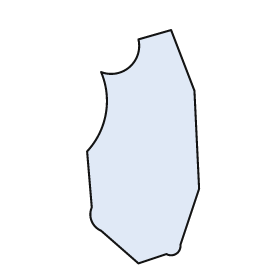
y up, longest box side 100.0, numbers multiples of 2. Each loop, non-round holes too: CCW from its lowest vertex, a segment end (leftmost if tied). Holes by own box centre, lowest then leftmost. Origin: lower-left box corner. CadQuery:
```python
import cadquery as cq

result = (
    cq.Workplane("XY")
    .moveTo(22.0, 0.0)
    .lineTo(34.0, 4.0)
    .threePointArc((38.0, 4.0), (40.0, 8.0))
    .lineTo(48.0, 32.0)
    .lineTo(46.0, 74.0)
    .lineTo(36.0, 100.0)
    .lineTo(22.0, 96.0)
    .threePointArc((18.0, 84.0), (6.0, 82.0))
    .threePointArc((8.0, 64.0), (0.0, 48.0))
    .lineTo(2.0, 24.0)
    .threePointArc((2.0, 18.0), (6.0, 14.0))
    .close()
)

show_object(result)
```